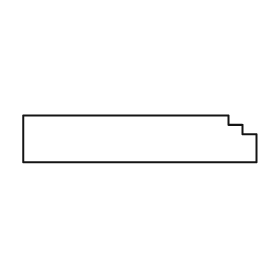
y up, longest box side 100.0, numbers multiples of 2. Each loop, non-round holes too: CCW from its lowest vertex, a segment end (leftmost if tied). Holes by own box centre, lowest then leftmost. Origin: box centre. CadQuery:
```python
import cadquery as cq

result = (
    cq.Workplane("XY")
    .moveTo(-50.0, -10.0)
    .lineTo(50.0, -10.0)
    .lineTo(50.0, 2.0)
    .lineTo(44.0, 2.0)
    .lineTo(44.0, 6.0)
    .lineTo(38.0, 6.0)
    .lineTo(38.0, 10.0)
    .lineTo(-50.0, 10.0)
    .close()
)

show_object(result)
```